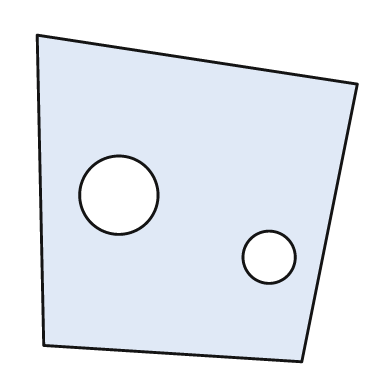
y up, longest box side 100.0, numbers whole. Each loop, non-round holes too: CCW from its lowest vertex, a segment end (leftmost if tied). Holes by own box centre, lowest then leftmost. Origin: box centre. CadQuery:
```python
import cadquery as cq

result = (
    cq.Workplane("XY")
    .moveTo(32.0, -50.0)
    .lineTo(49.0, 35.0)
    .lineTo(-49.0, 50.0)
    .lineTo(-47.0, -45.0)
    .close()
    .moveTo(22.0, -18.0)
    .circle(8.0)
    .moveTo(-24.0, 1.0)
    .circle(12.0)
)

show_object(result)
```